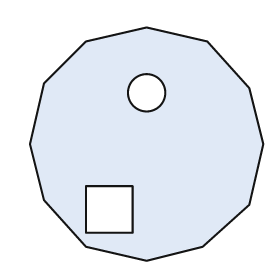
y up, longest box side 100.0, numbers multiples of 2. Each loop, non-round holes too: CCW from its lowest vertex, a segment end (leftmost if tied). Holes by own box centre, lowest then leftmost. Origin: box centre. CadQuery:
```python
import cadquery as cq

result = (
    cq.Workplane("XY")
    .moveTo(0.0, -50.0)
    .lineTo(24.0, -44.0)
    .lineTo(44.0, -26.0)
    .lineTo(50.0, 0.0)
    .lineTo(44.0, 24.0)
    .lineTo(26.0, 44.0)
    .lineTo(0.0, 50.0)
    .lineTo(-26.0, 44.0)
    .lineTo(-44.0, 26.0)
    .lineTo(-50.0, 0.0)
    .lineTo(-44.0, -24.0)
    .lineTo(-26.0, -44.0)
    .close()
    .moveTo(-26.0, -38.0)
    .lineTo(-6.0, -38.0)
    .lineTo(-6.0, -18.0)
    .lineTo(-26.0, -18.0)
    .close()
    .moveTo(0.0, 22.0)
    .circle(8.0)
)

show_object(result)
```